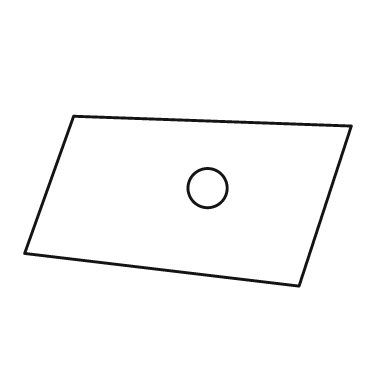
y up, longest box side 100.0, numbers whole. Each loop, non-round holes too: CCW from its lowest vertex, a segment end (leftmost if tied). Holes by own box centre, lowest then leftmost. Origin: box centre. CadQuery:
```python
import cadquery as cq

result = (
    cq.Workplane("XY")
    .moveTo(34.0, -26.0)
    .lineTo(50.0, 23.0)
    .lineTo(-35.0, 26.0)
    .lineTo(-50.0, -16.0)
    .close()
    .moveTo(6.0, 4.0)
    .circle(6.0)
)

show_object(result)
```